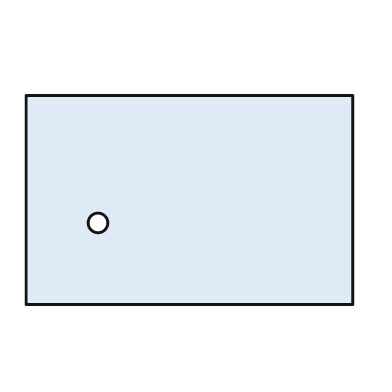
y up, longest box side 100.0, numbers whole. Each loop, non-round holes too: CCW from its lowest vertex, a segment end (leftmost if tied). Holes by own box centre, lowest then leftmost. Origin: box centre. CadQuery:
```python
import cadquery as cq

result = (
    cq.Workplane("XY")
    .moveTo(-50.0, -32.0)
    .lineTo(50.0, -32.0)
    .lineTo(50.0, 32.0)
    .lineTo(-50.0, 32.0)
    .close()
    .moveTo(-28.0, -7.0)
    .circle(3.0)
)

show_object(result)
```